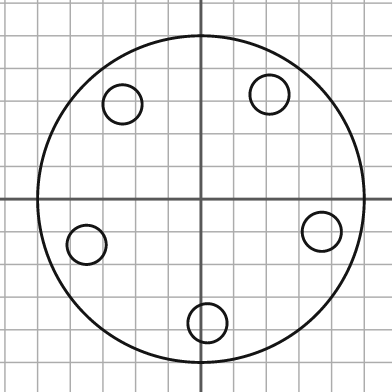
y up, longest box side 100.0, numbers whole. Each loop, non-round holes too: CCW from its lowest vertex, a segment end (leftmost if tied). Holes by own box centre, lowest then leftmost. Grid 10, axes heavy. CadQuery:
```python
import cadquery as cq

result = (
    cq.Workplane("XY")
    .moveTo(0.0, 0.0)
    .circle(50.0)
    .moveTo(2.0, -38.0)
    .circle(6.0)
    .moveTo(-35.0, -14.0)
    .circle(6.0)
    .moveTo(37.0, -10.0)
    .circle(6.0)
    .moveTo(-24.0, 29.0)
    .circle(6.0)
    .moveTo(21.0, 32.0)
    .circle(6.0)
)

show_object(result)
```